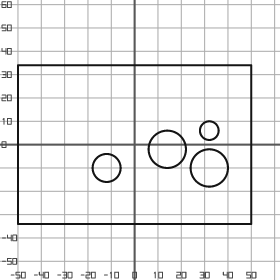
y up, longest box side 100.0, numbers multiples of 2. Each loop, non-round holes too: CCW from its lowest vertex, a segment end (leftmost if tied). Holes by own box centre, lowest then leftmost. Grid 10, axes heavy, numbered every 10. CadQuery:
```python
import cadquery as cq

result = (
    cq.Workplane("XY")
    .moveTo(-50.0, -34.0)
    .lineTo(50.0, -34.0)
    .lineTo(50.0, 34.0)
    .lineTo(-50.0, 34.0)
    .close()
    .moveTo(-12.0, -10.0)
    .circle(6.0)
    .moveTo(32.0, -10.0)
    .circle(8.0)
    .moveTo(14.0, -2.0)
    .circle(8.0)
    .moveTo(32.0, 6.0)
    .circle(4.0)
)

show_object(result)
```